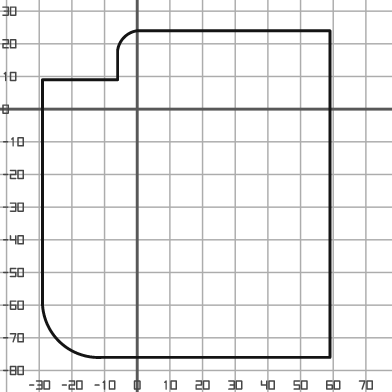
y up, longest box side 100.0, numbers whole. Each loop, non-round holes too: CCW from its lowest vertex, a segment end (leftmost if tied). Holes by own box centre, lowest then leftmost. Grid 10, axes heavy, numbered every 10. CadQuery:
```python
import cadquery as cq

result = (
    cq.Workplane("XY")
    .moveTo(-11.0, -76.0)
    .lineTo(59.0, -76.0)
    .lineTo(59.0, 24.0)
    .lineTo(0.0, 24.0)
    .threePointArc((-4.0, 22.0), (-6.0, 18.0))
    .lineTo(-6.0, 9.0)
    .lineTo(-29.0, 9.0)
    .lineTo(-29.0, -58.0)
    .threePointArc((-24.0, -71.0), (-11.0, -76.0))
    .close()
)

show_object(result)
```